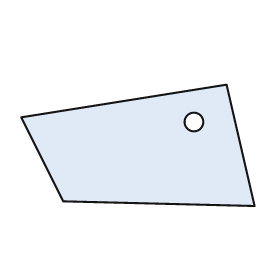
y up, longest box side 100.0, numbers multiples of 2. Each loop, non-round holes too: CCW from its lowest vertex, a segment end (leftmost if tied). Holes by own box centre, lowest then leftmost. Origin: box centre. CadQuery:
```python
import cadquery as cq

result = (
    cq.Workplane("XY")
    .moveTo(50.0, -26.0)
    .lineTo(38.0, 26.0)
    .lineTo(-50.0, 12.0)
    .lineTo(-32.0, -24.0)
    .close()
    .moveTo(24.0, 10.0)
    .circle(4.0)
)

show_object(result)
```